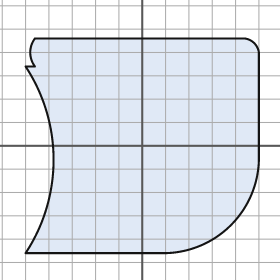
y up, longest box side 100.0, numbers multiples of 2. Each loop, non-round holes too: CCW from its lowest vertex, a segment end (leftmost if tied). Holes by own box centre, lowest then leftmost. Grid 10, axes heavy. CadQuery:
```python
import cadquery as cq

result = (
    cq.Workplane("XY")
    .moveTo(-50.0, -46.0)
    .lineTo(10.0, -46.0)
    .threePointArc((38.0, -34.0), (50.0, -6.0))
    .lineTo(50.0, 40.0)
    .threePointArc((48.0, 44.0), (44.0, 46.0))
    .lineTo(-46.0, 46.0)
    .threePointArc((-48.0, 40.0), (-46.0, 34.0))
    .lineTo(-50.0, 34.0)
    .threePointArc((-38.0, -6.0), (-50.0, -46.0))
    .close()
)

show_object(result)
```